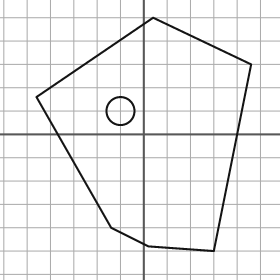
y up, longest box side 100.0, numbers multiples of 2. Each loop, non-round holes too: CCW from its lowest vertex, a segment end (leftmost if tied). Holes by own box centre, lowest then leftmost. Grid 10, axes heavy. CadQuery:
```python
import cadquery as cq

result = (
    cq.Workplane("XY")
    .moveTo(30.0, -50.0)
    .lineTo(46.0, 30.0)
    .lineTo(4.0, 50.0)
    .lineTo(-46.0, 16.0)
    .lineTo(-14.0, -40.0)
    .lineTo(2.0, -48.0)
    .close()
    .moveTo(-10.0, 10.0)
    .circle(6.0)
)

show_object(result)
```